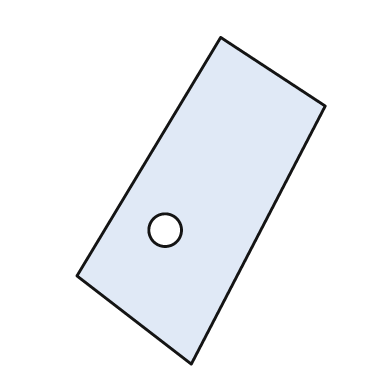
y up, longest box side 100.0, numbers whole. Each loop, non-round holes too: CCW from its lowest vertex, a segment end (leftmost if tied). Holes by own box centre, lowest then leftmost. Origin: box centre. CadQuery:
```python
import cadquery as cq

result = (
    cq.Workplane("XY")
    .moveTo(-3.0, -50.0)
    .lineTo(38.0, 29.0)
    .lineTo(6.0, 50.0)
    .lineTo(-38.0, -23.0)
    .close()
    .moveTo(-11.0, -9.0)
    .circle(5.0)
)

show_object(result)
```